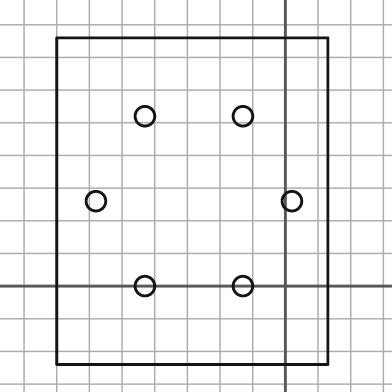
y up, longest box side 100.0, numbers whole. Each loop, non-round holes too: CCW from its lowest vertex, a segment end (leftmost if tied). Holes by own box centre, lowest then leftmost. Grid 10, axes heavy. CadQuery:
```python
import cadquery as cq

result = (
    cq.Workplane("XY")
    .moveTo(-70.0, -24.0)
    .lineTo(13.0, -24.0)
    .lineTo(13.0, 76.0)
    .lineTo(-70.0, 76.0)
    .close()
    .moveTo(-43.0, 0.0)
    .circle(3.0)
    .moveTo(-13.0, 0.0)
    .circle(3.0)
    .moveTo(-58.0, 26.0)
    .circle(3.0)
    .moveTo(2.0, 26.0)
    .circle(3.0)
    .moveTo(-43.0, 52.0)
    .circle(3.0)
    .moveTo(-13.0, 52.0)
    .circle(3.0)
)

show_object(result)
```